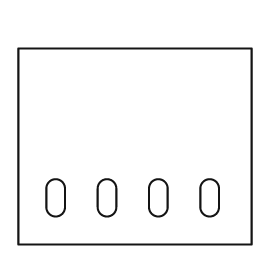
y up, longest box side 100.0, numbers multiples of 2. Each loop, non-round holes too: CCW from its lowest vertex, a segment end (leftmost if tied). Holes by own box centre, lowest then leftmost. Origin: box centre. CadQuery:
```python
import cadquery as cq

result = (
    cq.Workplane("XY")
    .moveTo(-50.0, -42.0)
    .lineTo(50.0, -42.0)
    .lineTo(50.0, 42.0)
    .lineTo(-50.0, 42.0)
    .close()
    .moveTo(-38.0, -26.0)
    .threePointArc((-34.0, -30.0), (-30.0, -26.0))
    .lineTo(-30.0, -18.0)
    .threePointArc((-34.0, -14.0), (-38.0, -18.0))
    .close()
    .moveTo(-16.0, -26.0)
    .threePointArc((-12.0, -30.0), (-8.0, -26.0))
    .lineTo(-8.0, -18.0)
    .threePointArc((-12.0, -14.0), (-16.0, -18.0))
    .close()
    .moveTo(6.0, -26.0)
    .threePointArc((10.0, -30.0), (14.0, -26.0))
    .lineTo(14.0, -18.0)
    .threePointArc((10.0, -14.0), (6.0, -18.0))
    .close()
    .moveTo(28.0, -26.0)
    .threePointArc((32.0, -30.0), (36.0, -26.0))
    .lineTo(36.0, -18.0)
    .threePointArc((32.0, -14.0), (28.0, -18.0))
    .close()
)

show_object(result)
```